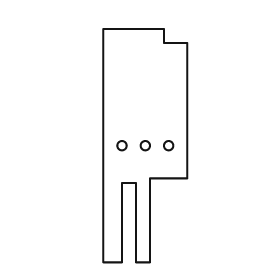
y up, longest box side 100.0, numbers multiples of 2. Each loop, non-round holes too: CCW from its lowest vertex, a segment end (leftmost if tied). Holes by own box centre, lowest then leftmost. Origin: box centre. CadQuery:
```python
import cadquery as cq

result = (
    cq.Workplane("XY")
    .moveTo(-18.0, -50.0)
    .lineTo(-10.0, -50.0)
    .lineTo(-10.0, -16.0)
    .lineTo(-4.0, -16.0)
    .lineTo(-4.0, -50.0)
    .lineTo(2.0, -50.0)
    .lineTo(2.0, -14.0)
    .lineTo(18.0, -14.0)
    .lineTo(18.0, 44.0)
    .lineTo(8.0, 44.0)
    .lineTo(8.0, 50.0)
    .lineTo(-18.0, 50.0)
    .close()
    .moveTo(-10.0, 0.0)
    .circle(2.0)
    .moveTo(0.0, 0.0)
    .circle(2.0)
    .moveTo(10.0, 0.0)
    .circle(2.0)
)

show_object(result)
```